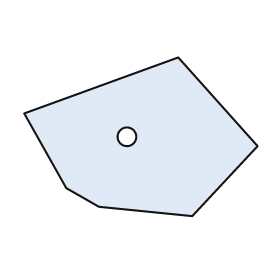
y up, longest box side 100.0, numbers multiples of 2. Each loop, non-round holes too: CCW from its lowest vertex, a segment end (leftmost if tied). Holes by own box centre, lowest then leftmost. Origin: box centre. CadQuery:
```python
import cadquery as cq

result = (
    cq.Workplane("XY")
    .moveTo(22.0, -34.0)
    .lineTo(50.0, -4.0)
    .lineTo(16.0, 34.0)
    .lineTo(-50.0, 10.0)
    .lineTo(-32.0, -22.0)
    .lineTo(-18.0, -30.0)
    .close()
    .moveTo(-6.0, 0.0)
    .circle(4.0)
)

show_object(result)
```